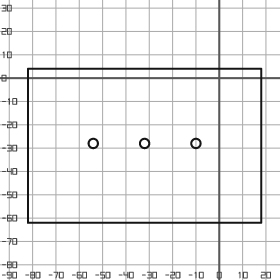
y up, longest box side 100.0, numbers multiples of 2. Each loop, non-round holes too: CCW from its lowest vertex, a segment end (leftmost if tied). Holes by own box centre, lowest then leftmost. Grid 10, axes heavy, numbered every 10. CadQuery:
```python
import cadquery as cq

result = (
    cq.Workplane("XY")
    .moveTo(-82.0, -62.0)
    .lineTo(18.0, -62.0)
    .lineTo(18.0, 4.0)
    .lineTo(-82.0, 4.0)
    .close()
    .moveTo(-54.0, -28.0)
    .circle(2.0)
    .moveTo(-32.0, -28.0)
    .circle(2.0)
    .moveTo(-10.0, -28.0)
    .circle(2.0)
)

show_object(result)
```